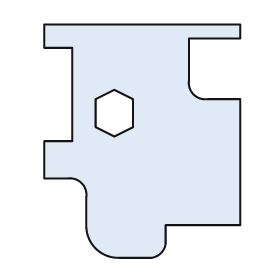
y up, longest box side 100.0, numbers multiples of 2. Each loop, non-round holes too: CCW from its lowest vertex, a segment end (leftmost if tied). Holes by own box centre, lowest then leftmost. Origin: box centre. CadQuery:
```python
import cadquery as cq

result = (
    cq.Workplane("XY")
    .moveTo(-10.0, -50.0)
    .lineTo(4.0, -50.0)
    .threePointArc((8.0, -48.0), (10.0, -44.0))
    .lineTo(10.0, -36.0)
    .lineTo(42.0, -36.0)
    .lineTo(42.0, 18.0)
    .lineTo(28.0, 18.0)
    .threePointArc((22.0, 20.0), (20.0, 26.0))
    .lineTo(20.0, 44.0)
    .lineTo(42.0, 44.0)
    .lineTo(42.0, 50.0)
    .lineTo(-42.0, 50.0)
    .lineTo(-42.0, 40.0)
    .lineTo(-30.0, 40.0)
    .lineTo(-30.0, 0.0)
    .lineTo(-42.0, 0.0)
    .lineTo(-42.0, -16.0)
    .lineTo(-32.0, -16.0)
    .threePointArc((-26.0, -18.0), (-24.0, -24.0))
    .lineTo(-24.0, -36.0)
    .threePointArc((-20.0, -46.0), (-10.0, -50.0))
    .close()
    .moveTo(-12.0, 2.0)
    .lineTo(-4.0, 6.0)
    .lineTo(-4.0, 18.0)
    .lineTo(-12.0, 22.0)
    .lineTo(-20.0, 18.0)
    .lineTo(-20.0, 6.0)
    .close()
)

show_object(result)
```